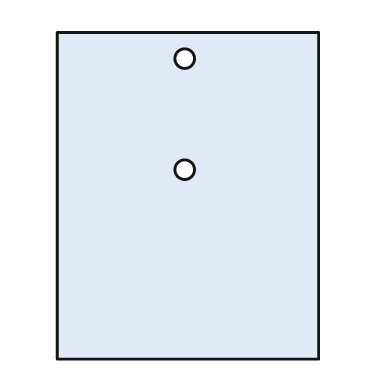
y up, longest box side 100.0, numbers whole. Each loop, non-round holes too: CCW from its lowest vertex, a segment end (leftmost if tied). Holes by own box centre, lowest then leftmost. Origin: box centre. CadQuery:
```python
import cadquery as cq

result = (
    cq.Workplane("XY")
    .moveTo(-40.0, -50.0)
    .lineTo(40.0, -50.0)
    .lineTo(40.0, 50.0)
    .lineTo(-40.0, 50.0)
    .close()
    .moveTo(-1.0, 8.0)
    .circle(3.0)
    .moveTo(-1.0, 42.0)
    .circle(3.0)
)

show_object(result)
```